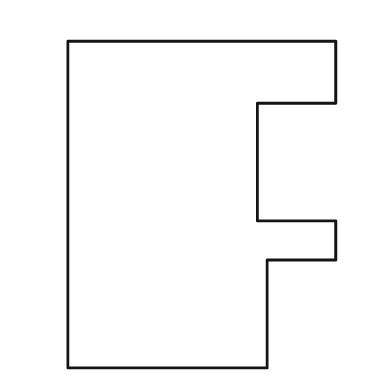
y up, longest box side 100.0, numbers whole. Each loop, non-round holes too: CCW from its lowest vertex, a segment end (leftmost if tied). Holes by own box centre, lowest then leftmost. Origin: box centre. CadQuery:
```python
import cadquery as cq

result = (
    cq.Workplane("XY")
    .moveTo(-41.0, -50.0)
    .lineTo(20.0, -50.0)
    .lineTo(20.0, -17.0)
    .lineTo(41.0, -17.0)
    .lineTo(41.0, -5.0)
    .lineTo(17.0, -5.0)
    .lineTo(17.0, 31.0)
    .lineTo(41.0, 31.0)
    .lineTo(41.0, 50.0)
    .lineTo(-41.0, 50.0)
    .close()
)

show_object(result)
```